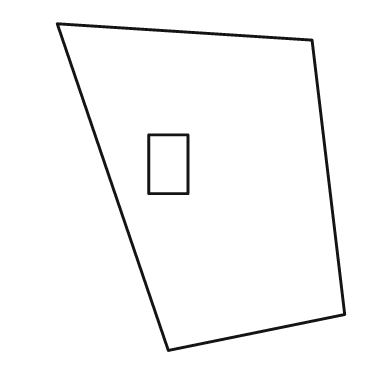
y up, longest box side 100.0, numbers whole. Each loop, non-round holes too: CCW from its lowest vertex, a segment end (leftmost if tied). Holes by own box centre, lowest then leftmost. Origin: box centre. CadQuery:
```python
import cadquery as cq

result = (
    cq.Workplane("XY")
    .moveTo(-10.0, -50.0)
    .lineTo(44.0, -39.0)
    .lineTo(34.0, 45.0)
    .lineTo(-44.0, 50.0)
    .close()
    .moveTo(-16.0, -2.0)
    .lineTo(-4.0, -2.0)
    .lineTo(-4.0, 16.0)
    .lineTo(-16.0, 16.0)
    .close()
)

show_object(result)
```